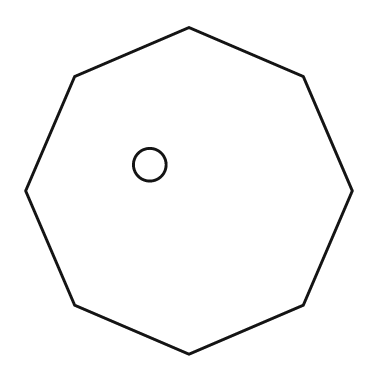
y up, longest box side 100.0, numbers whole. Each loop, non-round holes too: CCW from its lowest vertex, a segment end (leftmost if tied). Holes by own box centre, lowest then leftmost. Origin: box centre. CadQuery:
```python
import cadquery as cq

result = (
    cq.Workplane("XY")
    .moveTo(0.0, -50.0)
    .lineTo(35.0, -35.0)
    .lineTo(50.0, 0.0)
    .lineTo(35.0, 35.0)
    .lineTo(0.0, 50.0)
    .lineTo(-35.0, 35.0)
    .lineTo(-50.0, 0.0)
    .lineTo(-35.0, -35.0)
    .close()
    .moveTo(-12.0, 8.0)
    .circle(5.0)
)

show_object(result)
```